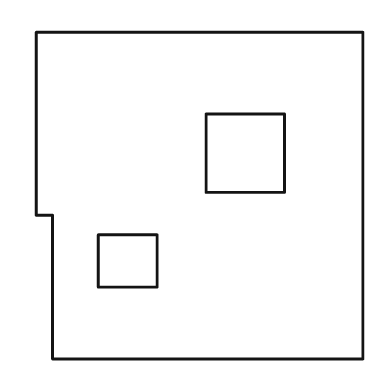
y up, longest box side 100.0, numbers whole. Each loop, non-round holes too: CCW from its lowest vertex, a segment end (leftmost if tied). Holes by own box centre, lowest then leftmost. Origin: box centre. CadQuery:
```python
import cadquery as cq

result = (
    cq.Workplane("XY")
    .moveTo(-45.0, -50.0)
    .lineTo(50.0, -50.0)
    .lineTo(50.0, 50.0)
    .lineTo(-50.0, 50.0)
    .lineTo(-50.0, -6.0)
    .lineTo(-45.0, -6.0)
    .close()
    .moveTo(-31.0, -28.0)
    .lineTo(-13.0, -28.0)
    .lineTo(-13.0, -12.0)
    .lineTo(-31.0, -12.0)
    .close()
    .moveTo(2.0, 1.0)
    .lineTo(26.0, 1.0)
    .lineTo(26.0, 25.0)
    .lineTo(2.0, 25.0)
    .close()
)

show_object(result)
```